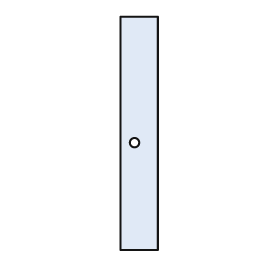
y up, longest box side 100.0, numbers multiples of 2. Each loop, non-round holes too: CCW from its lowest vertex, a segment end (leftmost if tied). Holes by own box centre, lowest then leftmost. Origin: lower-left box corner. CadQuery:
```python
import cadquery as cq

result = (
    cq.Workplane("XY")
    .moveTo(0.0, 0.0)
    .lineTo(16.0, 0.0)
    .lineTo(16.0, 100.0)
    .lineTo(0.0, 100.0)
    .close()
    .moveTo(6.0, 46.0)
    .circle(2.0)
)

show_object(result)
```